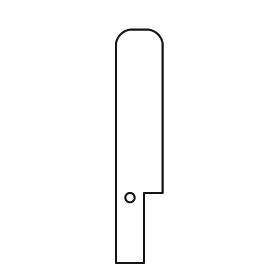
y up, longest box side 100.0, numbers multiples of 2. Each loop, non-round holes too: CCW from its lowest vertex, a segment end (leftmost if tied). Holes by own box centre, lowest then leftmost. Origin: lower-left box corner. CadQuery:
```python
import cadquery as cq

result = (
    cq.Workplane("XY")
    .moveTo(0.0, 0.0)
    .lineTo(12.0, 0.0)
    .lineTo(12.0, 30.0)
    .lineTo(20.0, 30.0)
    .lineTo(20.0, 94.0)
    .threePointArc((18.0, 98.0), (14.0, 100.0))
    .lineTo(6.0, 100.0)
    .threePointArc((2.0, 98.0), (0.0, 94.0))
    .close()
    .moveTo(6.0, 28.0)
    .circle(2.0)
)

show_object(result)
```